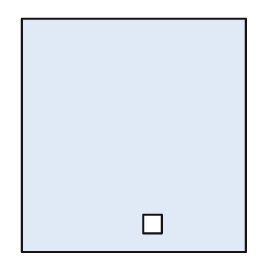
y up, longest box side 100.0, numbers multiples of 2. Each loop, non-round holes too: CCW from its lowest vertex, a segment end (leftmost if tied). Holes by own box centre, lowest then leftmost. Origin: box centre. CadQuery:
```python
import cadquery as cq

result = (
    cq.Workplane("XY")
    .moveTo(-48.0, -50.0)
    .lineTo(48.0, -50.0)
    .lineTo(48.0, 50.0)
    .lineTo(-48.0, 50.0)
    .close()
    .moveTo(4.0, -42.0)
    .lineTo(12.0, -42.0)
    .lineTo(12.0, -34.0)
    .lineTo(4.0, -34.0)
    .close()
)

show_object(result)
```